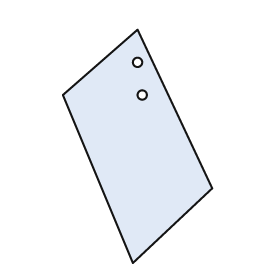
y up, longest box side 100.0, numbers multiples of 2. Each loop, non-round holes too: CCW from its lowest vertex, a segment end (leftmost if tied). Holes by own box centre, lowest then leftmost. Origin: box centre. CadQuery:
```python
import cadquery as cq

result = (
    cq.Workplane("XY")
    .moveTo(-2.0, -50.0)
    .lineTo(32.0, -18.0)
    .lineTo(0.0, 50.0)
    .lineTo(-32.0, 22.0)
    .close()
    .moveTo(2.0, 22.0)
    .circle(2.0)
    .moveTo(0.0, 36.0)
    .circle(2.0)
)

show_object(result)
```